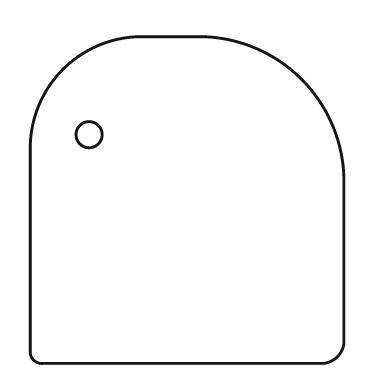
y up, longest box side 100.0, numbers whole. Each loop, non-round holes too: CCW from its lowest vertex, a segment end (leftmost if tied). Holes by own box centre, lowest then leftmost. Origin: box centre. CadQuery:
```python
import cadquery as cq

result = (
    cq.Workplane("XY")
    .moveTo(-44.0, -50.0)
    .lineTo(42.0, -50.0)
    .threePointArc((46.0, -48.0), (48.0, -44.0))
    .lineTo(48.0, 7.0)
    .threePointArc((35.0, 37.0), (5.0, 50.0))
    .lineTo(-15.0, 50.0)
    .threePointArc((-38.0, 40.0), (-48.0, 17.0))
    .lineTo(-48.0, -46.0)
    .threePointArc((-47.0, -49.0), (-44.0, -50.0))
    .close()
    .moveTo(-30.0, 20.0)
    .circle(4.0)
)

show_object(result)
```